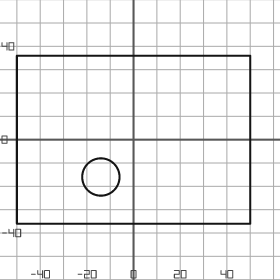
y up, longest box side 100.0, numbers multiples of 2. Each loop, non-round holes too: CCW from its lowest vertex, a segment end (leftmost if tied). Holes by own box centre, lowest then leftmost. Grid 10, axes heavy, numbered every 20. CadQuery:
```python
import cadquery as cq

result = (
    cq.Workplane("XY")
    .moveTo(-50.0, -36.0)
    .lineTo(50.0, -36.0)
    .lineTo(50.0, 36.0)
    .lineTo(-50.0, 36.0)
    .close()
    .moveTo(-14.0, -16.0)
    .circle(8.0)
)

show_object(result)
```